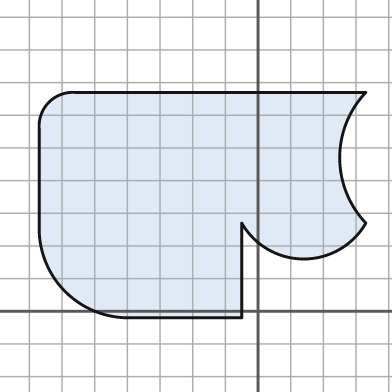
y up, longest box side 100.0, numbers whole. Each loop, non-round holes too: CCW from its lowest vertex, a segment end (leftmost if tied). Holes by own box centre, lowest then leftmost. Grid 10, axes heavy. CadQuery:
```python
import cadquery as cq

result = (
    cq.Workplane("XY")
    .moveTo(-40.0, -2.0)
    .lineTo(-5.0, -2.0)
    .lineTo(-5.0, 27.0)
    .threePointArc((14.0, 16.0), (33.0, 27.0))
    .threePointArc((25.0, 47.0), (33.0, 67.0))
    .lineTo(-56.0, 67.0)
    .threePointArc((-64.0, 64.0), (-67.0, 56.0))
    .lineTo(-67.0, 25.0)
    .threePointArc((-59.0, 6.0), (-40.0, -2.0))
    .close()
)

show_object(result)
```